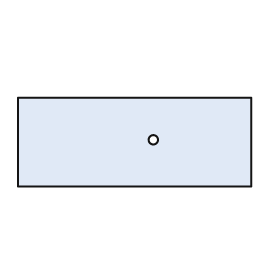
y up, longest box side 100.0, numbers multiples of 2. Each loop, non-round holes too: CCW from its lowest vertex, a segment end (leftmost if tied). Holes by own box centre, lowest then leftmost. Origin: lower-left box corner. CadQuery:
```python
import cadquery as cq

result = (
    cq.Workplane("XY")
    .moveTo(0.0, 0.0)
    .lineTo(100.0, 0.0)
    .lineTo(100.0, 38.0)
    .lineTo(0.0, 38.0)
    .close()
    .moveTo(58.0, 20.0)
    .circle(2.0)
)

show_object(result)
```